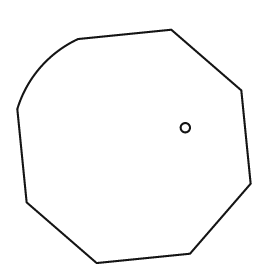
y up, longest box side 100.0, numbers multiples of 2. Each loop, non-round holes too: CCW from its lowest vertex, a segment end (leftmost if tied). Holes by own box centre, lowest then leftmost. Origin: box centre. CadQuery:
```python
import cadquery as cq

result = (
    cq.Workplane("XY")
    .moveTo(-16.0, -50.0)
    .lineTo(24.0, -46.0)
    .lineTo(50.0, -16.0)
    .lineTo(46.0, 24.0)
    .lineTo(16.0, 50.0)
    .lineTo(-24.0, 46.0)
    .threePointArc((-40.0, 34.0), (-50.0, 16.0))
    .lineTo(-46.0, -24.0)
    .close()
    .moveTo(22.0, 8.0)
    .circle(2.0)
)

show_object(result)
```